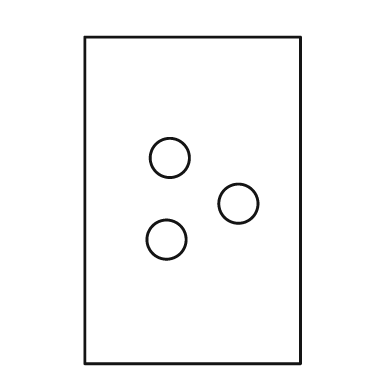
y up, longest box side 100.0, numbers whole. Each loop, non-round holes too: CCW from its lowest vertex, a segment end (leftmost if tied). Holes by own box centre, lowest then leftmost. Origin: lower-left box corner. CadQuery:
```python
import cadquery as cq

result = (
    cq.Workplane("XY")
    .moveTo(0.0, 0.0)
    .lineTo(66.0, 0.0)
    .lineTo(66.0, 100.0)
    .lineTo(0.0, 100.0)
    .close()
    .moveTo(25.0, 38.0)
    .circle(6.0)
    .moveTo(47.0, 49.0)
    .circle(6.0)
    .moveTo(26.0, 63.0)
    .circle(6.0)
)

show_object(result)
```